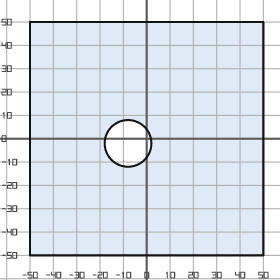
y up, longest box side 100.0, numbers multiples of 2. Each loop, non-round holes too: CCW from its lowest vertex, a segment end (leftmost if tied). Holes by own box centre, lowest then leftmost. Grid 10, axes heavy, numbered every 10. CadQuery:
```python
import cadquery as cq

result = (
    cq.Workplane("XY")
    .moveTo(-50.0, -50.0)
    .lineTo(50.0, -50.0)
    .lineTo(50.0, 50.0)
    .lineTo(-50.0, 50.0)
    .close()
    .moveTo(-8.0, -2.0)
    .circle(10.0)
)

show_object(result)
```